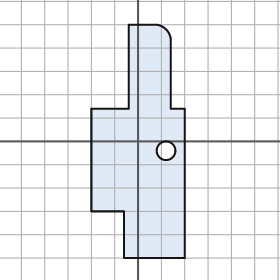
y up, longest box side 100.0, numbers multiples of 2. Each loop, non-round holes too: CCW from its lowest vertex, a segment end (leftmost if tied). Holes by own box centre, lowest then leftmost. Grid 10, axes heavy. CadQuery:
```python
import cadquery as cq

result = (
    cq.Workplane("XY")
    .moveTo(-6.0, -50.0)
    .lineTo(20.0, -50.0)
    .lineTo(20.0, 14.0)
    .lineTo(14.0, 14.0)
    .lineTo(14.0, 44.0)
    .threePointArc((12.0, 48.0), (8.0, 50.0))
    .lineTo(-4.0, 50.0)
    .lineTo(-4.0, 14.0)
    .lineTo(-20.0, 14.0)
    .lineTo(-20.0, -30.0)
    .lineTo(-6.0, -30.0)
    .close()
    .moveTo(12.0, -4.0)
    .circle(4.0)
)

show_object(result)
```